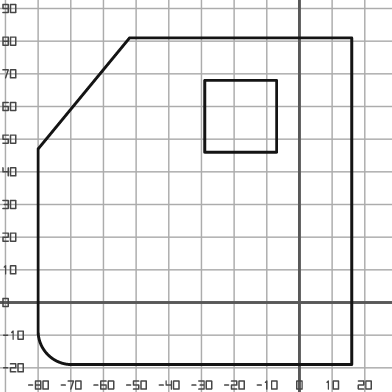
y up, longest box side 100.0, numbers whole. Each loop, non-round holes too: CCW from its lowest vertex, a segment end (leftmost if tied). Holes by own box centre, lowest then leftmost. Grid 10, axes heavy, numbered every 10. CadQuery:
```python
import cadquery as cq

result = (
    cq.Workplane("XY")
    .moveTo(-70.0, -19.0)
    .lineTo(16.0, -19.0)
    .lineTo(16.0, 81.0)
    .lineTo(-52.0, 81.0)
    .lineTo(-80.0, 47.0)
    .lineTo(-80.0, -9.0)
    .threePointArc((-77.0, -16.0), (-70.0, -19.0))
    .close()
    .moveTo(-29.0, 46.0)
    .lineTo(-7.0, 46.0)
    .lineTo(-7.0, 68.0)
    .lineTo(-29.0, 68.0)
    .close()
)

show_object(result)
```